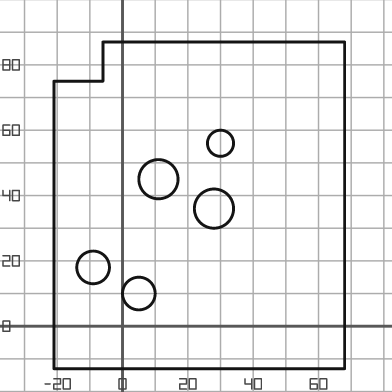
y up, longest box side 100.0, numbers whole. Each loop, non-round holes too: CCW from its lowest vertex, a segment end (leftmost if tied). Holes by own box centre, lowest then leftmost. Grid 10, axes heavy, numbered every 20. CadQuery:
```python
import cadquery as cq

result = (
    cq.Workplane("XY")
    .moveTo(-21.0, -13.0)
    .lineTo(68.0, -13.0)
    .lineTo(68.0, 87.0)
    .lineTo(-6.0, 87.0)
    .lineTo(-6.0, 75.0)
    .lineTo(-21.0, 75.0)
    .close()
    .moveTo(5.0, 10.0)
    .circle(5.0)
    .moveTo(-9.0, 18.0)
    .circle(5.0)
    .moveTo(28.0, 36.0)
    .circle(6.0)
    .moveTo(11.0, 45.0)
    .circle(6.0)
    .moveTo(30.0, 56.0)
    .circle(4.0)
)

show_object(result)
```